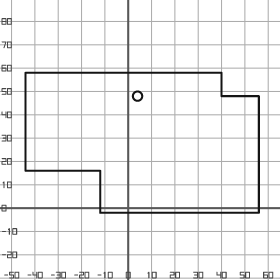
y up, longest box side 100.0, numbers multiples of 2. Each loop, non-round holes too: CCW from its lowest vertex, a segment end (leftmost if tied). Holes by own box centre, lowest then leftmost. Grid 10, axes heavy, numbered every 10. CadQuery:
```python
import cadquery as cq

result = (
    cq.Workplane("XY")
    .moveTo(-12.0, -2.0)
    .lineTo(56.0, -2.0)
    .lineTo(56.0, 48.0)
    .lineTo(40.0, 48.0)
    .lineTo(40.0, 58.0)
    .lineTo(-44.0, 58.0)
    .lineTo(-44.0, 16.0)
    .lineTo(-12.0, 16.0)
    .close()
    .moveTo(4.0, 48.0)
    .circle(2.0)
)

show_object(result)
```